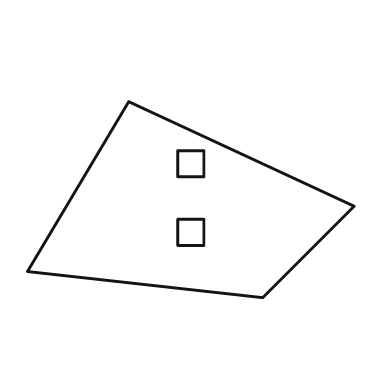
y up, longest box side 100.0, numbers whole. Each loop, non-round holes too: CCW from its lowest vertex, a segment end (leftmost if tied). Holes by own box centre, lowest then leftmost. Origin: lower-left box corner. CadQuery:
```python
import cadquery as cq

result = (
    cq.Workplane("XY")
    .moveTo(72.0, 0.0)
    .lineTo(100.0, 28.0)
    .lineTo(31.0, 60.0)
    .lineTo(0.0, 8.0)
    .close()
    .moveTo(46.0, 16.0)
    .lineTo(54.0, 16.0)
    .lineTo(54.0, 24.0)
    .lineTo(46.0, 24.0)
    .close()
    .moveTo(46.0, 37.0)
    .lineTo(54.0, 37.0)
    .lineTo(54.0, 45.0)
    .lineTo(46.0, 45.0)
    .close()
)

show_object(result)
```